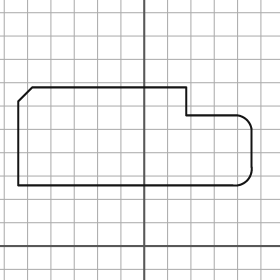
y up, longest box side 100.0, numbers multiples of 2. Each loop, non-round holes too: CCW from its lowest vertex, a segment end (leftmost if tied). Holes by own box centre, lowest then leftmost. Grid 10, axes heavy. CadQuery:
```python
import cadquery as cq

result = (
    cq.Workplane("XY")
    .moveTo(-54.0, 26.0)
    .lineTo(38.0, 26.0)
    .threePointArc((44.0, 28.0), (46.0, 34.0))
    .lineTo(46.0, 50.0)
    .threePointArc((44.0, 54.0), (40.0, 56.0))
    .lineTo(18.0, 56.0)
    .lineTo(18.0, 68.0)
    .lineTo(-48.0, 68.0)
    .lineTo(-54.0, 62.0)
    .close()
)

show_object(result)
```